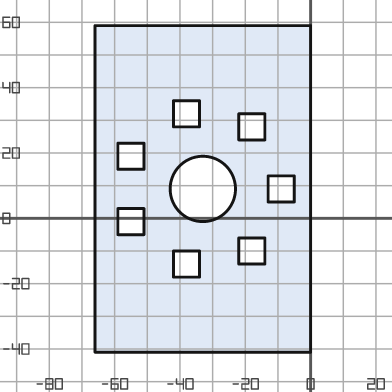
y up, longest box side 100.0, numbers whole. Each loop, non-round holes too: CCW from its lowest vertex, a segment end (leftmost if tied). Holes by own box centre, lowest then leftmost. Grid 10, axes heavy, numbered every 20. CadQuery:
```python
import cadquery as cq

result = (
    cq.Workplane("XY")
    .moveTo(-66.0, -41.0)
    .lineTo(0.0, -41.0)
    .lineTo(0.0, 59.0)
    .lineTo(-66.0, 59.0)
    .close()
    .moveTo(-42.0, -18.0)
    .lineTo(-34.0, -18.0)
    .lineTo(-34.0, -10.0)
    .lineTo(-42.0, -10.0)
    .close()
    .moveTo(-22.0, -14.0)
    .lineTo(-14.0, -14.0)
    .lineTo(-14.0, -6.0)
    .lineTo(-22.0, -6.0)
    .close()
    .moveTo(-59.0, -5.0)
    .lineTo(-51.0, -5.0)
    .lineTo(-51.0, 3.0)
    .lineTo(-59.0, 3.0)
    .close()
    .moveTo(-33.0, 9.0)
    .circle(10.0)
    .moveTo(-13.0, 5.0)
    .lineTo(-5.0, 5.0)
    .lineTo(-5.0, 13.0)
    .lineTo(-13.0, 13.0)
    .close()
    .moveTo(-59.0, 15.0)
    .lineTo(-51.0, 15.0)
    .lineTo(-51.0, 23.0)
    .lineTo(-59.0, 23.0)
    .close()
    .moveTo(-22.0, 24.0)
    .lineTo(-14.0, 24.0)
    .lineTo(-14.0, 32.0)
    .lineTo(-22.0, 32.0)
    .close()
    .moveTo(-42.0, 28.0)
    .lineTo(-34.0, 28.0)
    .lineTo(-34.0, 36.0)
    .lineTo(-42.0, 36.0)
    .close()
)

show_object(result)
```